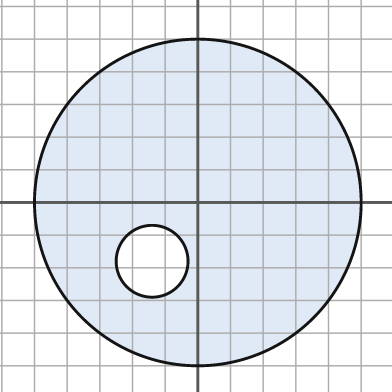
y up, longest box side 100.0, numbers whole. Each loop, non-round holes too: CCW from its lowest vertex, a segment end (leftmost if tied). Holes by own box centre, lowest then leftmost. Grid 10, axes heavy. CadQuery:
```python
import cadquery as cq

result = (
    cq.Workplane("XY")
    .moveTo(0.0, 0.0)
    .circle(50.0)
    .moveTo(-14.0, -18.0)
    .circle(11.0)
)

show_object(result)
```